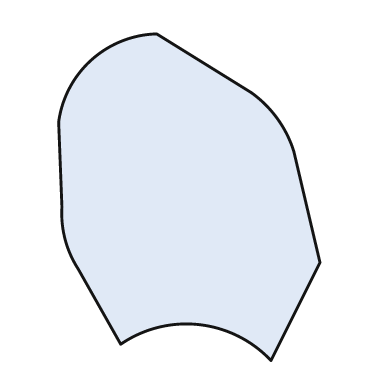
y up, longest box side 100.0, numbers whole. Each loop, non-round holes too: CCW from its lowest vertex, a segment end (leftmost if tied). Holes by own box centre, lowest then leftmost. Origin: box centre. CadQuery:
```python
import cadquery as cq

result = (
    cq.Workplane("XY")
    .moveTo(25.0, -50.0)
    .lineTo(40.0, -20.0)
    .lineTo(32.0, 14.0)
    .threePointArc((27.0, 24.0), (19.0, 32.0))
    .lineTo(-10.0, 50.0)
    .threePointArc((-30.0, 42.0), (-40.0, 23.0))
    .lineTo(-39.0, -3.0)
    .threePointArc((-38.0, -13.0), (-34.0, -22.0))
    .lineTo(-21.0, -45.0)
    .threePointArc((3.0, -39.0), (25.0, -50.0))
    .close()
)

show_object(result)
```